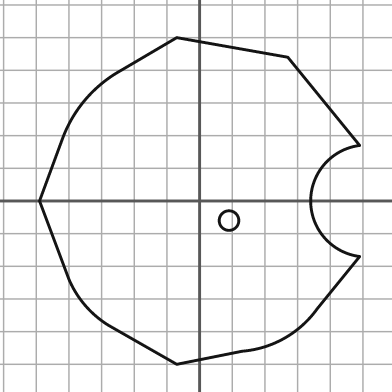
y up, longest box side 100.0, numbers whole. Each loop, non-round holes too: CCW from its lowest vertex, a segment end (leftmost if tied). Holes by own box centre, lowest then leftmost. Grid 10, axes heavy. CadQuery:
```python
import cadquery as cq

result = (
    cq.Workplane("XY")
    .moveTo(-7.0, -50.0)
    .lineTo(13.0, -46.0)
    .threePointArc((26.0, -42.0), (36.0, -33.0))
    .lineTo(49.0, -17.0)
    .threePointArc((34.0, 0.0), (49.0, 17.0))
    .lineTo(27.0, 44.0)
    .lineTo(-7.0, 50.0)
    .lineTo(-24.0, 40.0)
    .threePointArc((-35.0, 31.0), (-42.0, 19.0))
    .lineTo(-49.0, 0.0)
    .lineTo(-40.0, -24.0)
    .threePointArc((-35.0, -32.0), (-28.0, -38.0))
    .close()
    .moveTo(9.0, -6.0)
    .circle(3.0)
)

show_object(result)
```